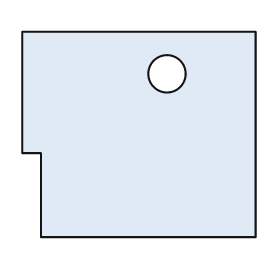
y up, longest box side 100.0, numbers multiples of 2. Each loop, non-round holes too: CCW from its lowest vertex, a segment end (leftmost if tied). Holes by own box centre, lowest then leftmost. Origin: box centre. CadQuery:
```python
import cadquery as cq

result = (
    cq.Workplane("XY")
    .moveTo(-42.0, -44.0)
    .lineTo(50.0, -44.0)
    .lineTo(50.0, 44.0)
    .lineTo(-50.0, 44.0)
    .lineTo(-50.0, -8.0)
    .lineTo(-42.0, -8.0)
    .close()
    .moveTo(12.0, 26.0)
    .circle(8.0)
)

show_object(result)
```